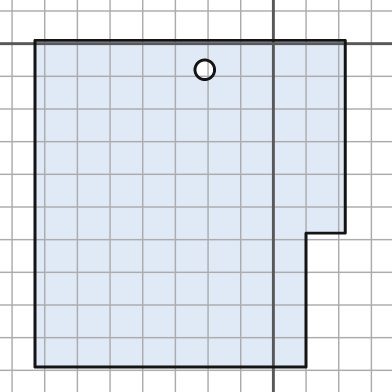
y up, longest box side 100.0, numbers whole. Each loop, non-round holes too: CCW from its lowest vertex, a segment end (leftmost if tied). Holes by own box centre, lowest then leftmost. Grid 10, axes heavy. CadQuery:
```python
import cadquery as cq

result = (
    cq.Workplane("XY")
    .moveTo(-73.0, -99.0)
    .lineTo(10.0, -99.0)
    .lineTo(10.0, -58.0)
    .lineTo(22.0, -58.0)
    .lineTo(22.0, 1.0)
    .lineTo(-73.0, 1.0)
    .close()
    .moveTo(-21.0, -8.0)
    .circle(3.0)
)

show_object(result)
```